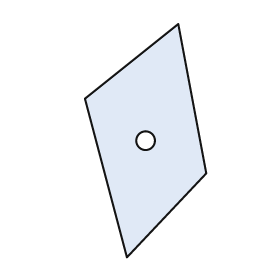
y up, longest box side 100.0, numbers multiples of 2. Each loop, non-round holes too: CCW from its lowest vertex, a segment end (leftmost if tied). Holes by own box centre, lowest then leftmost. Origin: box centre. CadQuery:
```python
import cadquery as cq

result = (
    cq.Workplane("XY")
    .moveTo(-8.0, -50.0)
    .lineTo(26.0, -14.0)
    .lineTo(14.0, 50.0)
    .lineTo(-26.0, 18.0)
    .close()
    .moveTo(0.0, 0.0)
    .circle(4.0)
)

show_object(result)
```